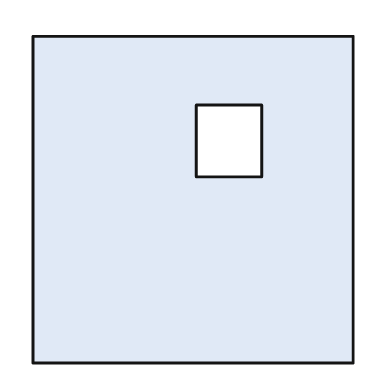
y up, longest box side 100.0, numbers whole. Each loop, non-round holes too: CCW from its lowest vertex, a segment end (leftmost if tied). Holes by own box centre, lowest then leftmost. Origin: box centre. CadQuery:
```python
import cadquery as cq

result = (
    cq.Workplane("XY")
    .moveTo(-49.0, -50.0)
    .lineTo(49.0, -50.0)
    .lineTo(49.0, 50.0)
    .lineTo(-49.0, 50.0)
    .close()
    .moveTo(1.0, 7.0)
    .lineTo(21.0, 7.0)
    .lineTo(21.0, 29.0)
    .lineTo(1.0, 29.0)
    .close()
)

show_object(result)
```